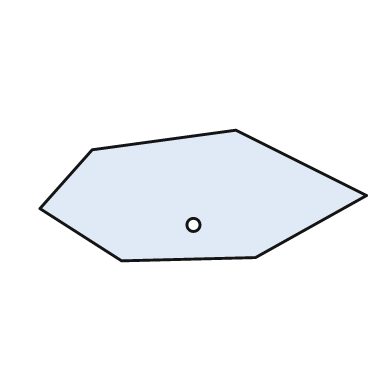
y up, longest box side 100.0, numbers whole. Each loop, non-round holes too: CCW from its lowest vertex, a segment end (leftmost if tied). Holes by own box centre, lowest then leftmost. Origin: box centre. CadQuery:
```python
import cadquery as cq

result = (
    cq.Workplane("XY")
    .moveTo(-25.0, -20.0)
    .lineTo(16.0, -19.0)
    .lineTo(50.0, 0.0)
    .lineTo(10.0, 20.0)
    .lineTo(-34.0, 14.0)
    .lineTo(-50.0, -4.0)
    .close()
    .moveTo(-3.0, -9.0)
    .circle(2.0)
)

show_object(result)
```